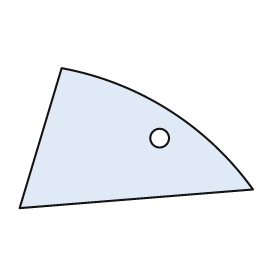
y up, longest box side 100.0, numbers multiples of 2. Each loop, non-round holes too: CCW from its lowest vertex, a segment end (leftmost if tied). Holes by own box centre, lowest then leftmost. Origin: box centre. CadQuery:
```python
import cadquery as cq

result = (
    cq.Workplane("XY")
    .moveTo(-50.0, -30.0)
    .lineTo(50.0, -22.0)
    .threePointArc((14.0, 12.0), (-32.0, 30.0))
    .close()
    .moveTo(10.0, 0.0)
    .circle(4.0)
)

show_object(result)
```